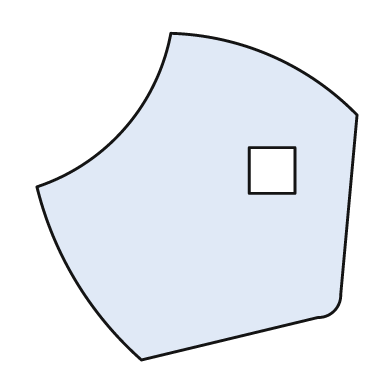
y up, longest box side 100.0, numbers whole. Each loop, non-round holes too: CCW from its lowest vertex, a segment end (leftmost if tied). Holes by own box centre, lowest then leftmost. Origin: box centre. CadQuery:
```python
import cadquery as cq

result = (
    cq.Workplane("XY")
    .moveTo(-17.0, -50.0)
    .lineTo(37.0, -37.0)
    .threePointArc((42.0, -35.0), (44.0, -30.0))
    .lineTo(49.0, 25.0)
    .threePointArc((23.0, 43.0), (-8.0, 50.0))
    .threePointArc((-22.0, 21.0), (-49.0, 3.0))
    .threePointArc((-37.0, -26.0), (-17.0, -50.0))
    .close()
    .moveTo(16.0, 1.0)
    .lineTo(30.0, 1.0)
    .lineTo(30.0, 15.0)
    .lineTo(16.0, 15.0)
    .close()
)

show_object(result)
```